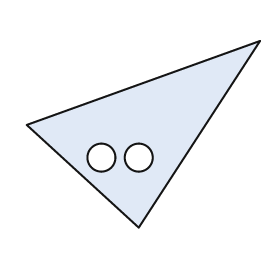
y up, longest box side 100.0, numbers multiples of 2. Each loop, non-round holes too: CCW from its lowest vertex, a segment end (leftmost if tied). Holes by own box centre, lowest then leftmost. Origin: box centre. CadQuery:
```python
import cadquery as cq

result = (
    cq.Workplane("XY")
    .moveTo(-2.0, -40.0)
    .lineTo(50.0, 40.0)
    .lineTo(-50.0, 4.0)
    .close()
    .moveTo(-18.0, -10.0)
    .circle(6.0)
    .moveTo(-2.0, -10.0)
    .circle(6.0)
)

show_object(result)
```